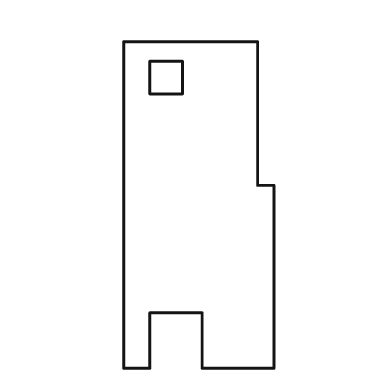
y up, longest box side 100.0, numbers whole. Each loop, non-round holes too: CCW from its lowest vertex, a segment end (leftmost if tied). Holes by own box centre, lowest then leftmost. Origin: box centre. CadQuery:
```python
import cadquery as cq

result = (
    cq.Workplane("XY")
    .moveTo(-23.0, -50.0)
    .lineTo(-15.0, -50.0)
    .lineTo(-15.0, -33.0)
    .lineTo(1.0, -33.0)
    .lineTo(1.0, -50.0)
    .lineTo(23.0, -50.0)
    .lineTo(23.0, 6.0)
    .lineTo(18.0, 6.0)
    .lineTo(18.0, 50.0)
    .lineTo(-23.0, 50.0)
    .close()
    .moveTo(-15.0, 34.0)
    .lineTo(-5.0, 34.0)
    .lineTo(-5.0, 44.0)
    .lineTo(-15.0, 44.0)
    .close()
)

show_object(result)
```